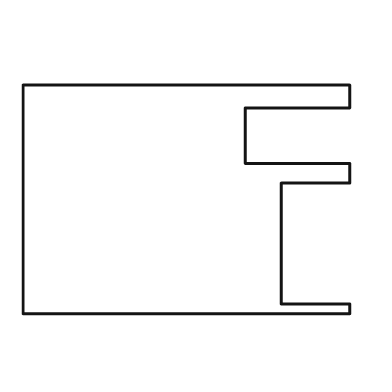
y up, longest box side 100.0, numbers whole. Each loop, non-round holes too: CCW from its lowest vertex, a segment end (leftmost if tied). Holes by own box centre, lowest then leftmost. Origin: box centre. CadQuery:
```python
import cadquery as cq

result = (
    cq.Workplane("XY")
    .moveTo(-50.0, -35.0)
    .lineTo(50.0, -35.0)
    .lineTo(50.0, -32.0)
    .lineTo(29.0, -32.0)
    .lineTo(29.0, 5.0)
    .lineTo(50.0, 5.0)
    .lineTo(50.0, 11.0)
    .lineTo(18.0, 11.0)
    .lineTo(18.0, 28.0)
    .lineTo(50.0, 28.0)
    .lineTo(50.0, 35.0)
    .lineTo(-50.0, 35.0)
    .close()
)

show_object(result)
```